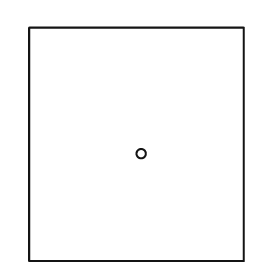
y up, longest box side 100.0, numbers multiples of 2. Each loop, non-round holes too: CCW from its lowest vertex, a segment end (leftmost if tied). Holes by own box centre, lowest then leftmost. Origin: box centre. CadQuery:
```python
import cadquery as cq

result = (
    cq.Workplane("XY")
    .moveTo(-46.0, -50.0)
    .lineTo(46.0, -50.0)
    .lineTo(46.0, 50.0)
    .lineTo(-46.0, 50.0)
    .close()
    .moveTo(2.0, -4.0)
    .circle(2.0)
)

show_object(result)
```